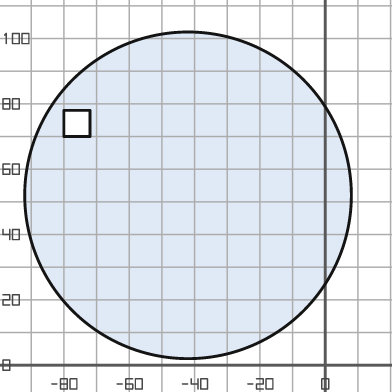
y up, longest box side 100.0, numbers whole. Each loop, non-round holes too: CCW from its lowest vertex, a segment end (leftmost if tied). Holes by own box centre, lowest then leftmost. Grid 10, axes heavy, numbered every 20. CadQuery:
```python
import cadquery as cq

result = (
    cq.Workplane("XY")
    .moveTo(-42.0, 52.0)
    .circle(50.0)
    .moveTo(-80.0, 70.0)
    .lineTo(-72.0, 70.0)
    .lineTo(-72.0, 78.0)
    .lineTo(-80.0, 78.0)
    .close()
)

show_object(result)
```